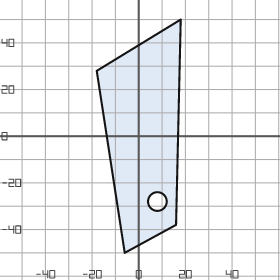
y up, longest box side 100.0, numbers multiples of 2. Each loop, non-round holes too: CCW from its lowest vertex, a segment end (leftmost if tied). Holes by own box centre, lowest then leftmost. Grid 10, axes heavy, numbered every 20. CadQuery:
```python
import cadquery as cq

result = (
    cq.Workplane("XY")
    .moveTo(-6.0, -50.0)
    .lineTo(16.0, -38.0)
    .lineTo(18.0, 50.0)
    .lineTo(-18.0, 28.0)
    .close()
    .moveTo(8.0, -28.0)
    .circle(4.0)
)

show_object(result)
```